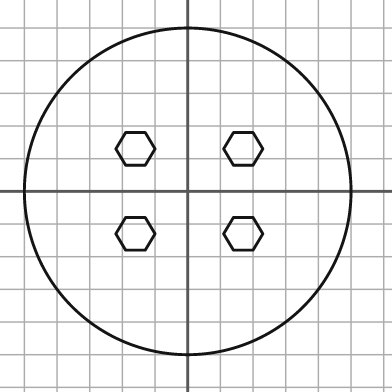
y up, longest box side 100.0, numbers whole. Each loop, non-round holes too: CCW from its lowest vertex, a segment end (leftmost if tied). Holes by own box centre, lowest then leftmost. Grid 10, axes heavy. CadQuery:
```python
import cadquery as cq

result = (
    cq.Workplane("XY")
    .moveTo(0.0, 0.0)
    .circle(50.0)
    .moveTo(-19.0, -18.0)
    .lineTo(-13.0, -18.0)
    .lineTo(-10.0, -13.0)
    .lineTo(-13.0, -8.0)
    .lineTo(-19.0, -8.0)
    .lineTo(-22.0, -13.0)
    .close()
    .moveTo(14.0, -18.0)
    .lineTo(20.0, -18.0)
    .lineTo(23.0, -13.0)
    .lineTo(20.0, -8.0)
    .lineTo(14.0, -8.0)
    .lineTo(11.0, -13.0)
    .close()
    .moveTo(-19.0, 8.0)
    .lineTo(-13.0, 8.0)
    .lineTo(-10.0, 13.0)
    .lineTo(-13.0, 18.0)
    .lineTo(-19.0, 18.0)
    .lineTo(-22.0, 13.0)
    .close()
    .moveTo(14.0, 8.0)
    .lineTo(20.0, 8.0)
    .lineTo(23.0, 13.0)
    .lineTo(20.0, 18.0)
    .lineTo(14.0, 18.0)
    .lineTo(11.0, 13.0)
    .close()
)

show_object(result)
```